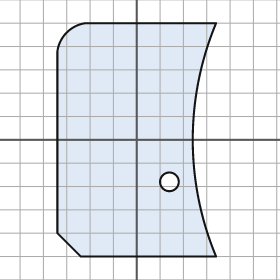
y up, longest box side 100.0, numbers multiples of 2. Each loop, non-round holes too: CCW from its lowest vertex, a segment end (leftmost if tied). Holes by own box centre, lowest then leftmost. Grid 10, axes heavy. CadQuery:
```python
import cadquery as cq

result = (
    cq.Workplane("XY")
    .moveTo(-24.0, -50.0)
    .lineTo(34.0, -50.0)
    .threePointArc((24.0, 0.0), (34.0, 50.0))
    .lineTo(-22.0, 50.0)
    .threePointArc((-30.0, 46.0), (-34.0, 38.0))
    .lineTo(-34.0, -40.0)
    .close()
    .moveTo(14.0, -18.0)
    .circle(4.0)
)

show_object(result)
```